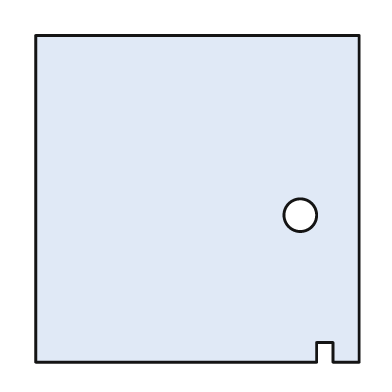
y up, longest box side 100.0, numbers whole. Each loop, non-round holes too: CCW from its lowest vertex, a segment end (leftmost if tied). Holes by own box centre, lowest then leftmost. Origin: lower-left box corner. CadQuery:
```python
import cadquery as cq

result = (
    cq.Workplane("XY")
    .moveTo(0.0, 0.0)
    .lineTo(86.0, 0.0)
    .lineTo(86.0, 6.0)
    .lineTo(91.0, 6.0)
    .lineTo(91.0, 0.0)
    .lineTo(99.0, 0.0)
    .lineTo(99.0, 100.0)
    .lineTo(0.0, 100.0)
    .close()
    .moveTo(81.0, 45.0)
    .circle(5.0)
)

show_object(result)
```